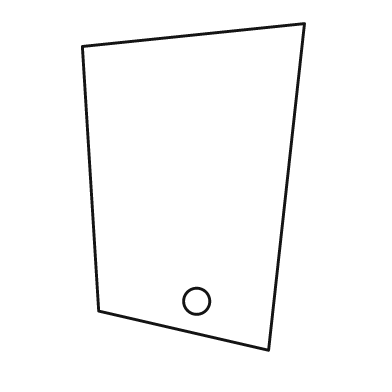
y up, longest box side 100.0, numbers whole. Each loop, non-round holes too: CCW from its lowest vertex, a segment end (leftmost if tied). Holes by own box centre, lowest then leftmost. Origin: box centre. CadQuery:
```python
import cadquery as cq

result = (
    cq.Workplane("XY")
    .moveTo(23.0, -50.0)
    .lineTo(34.0, 50.0)
    .lineTo(-34.0, 43.0)
    .lineTo(-29.0, -38.0)
    .close()
    .moveTo(1.0, -35.0)
    .circle(4.0)
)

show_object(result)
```